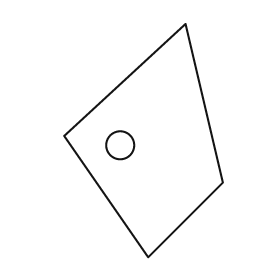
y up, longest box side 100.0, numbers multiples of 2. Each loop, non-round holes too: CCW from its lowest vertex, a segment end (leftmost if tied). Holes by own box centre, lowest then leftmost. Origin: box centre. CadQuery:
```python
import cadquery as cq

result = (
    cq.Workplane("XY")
    .moveTo(2.0, -50.0)
    .lineTo(34.0, -18.0)
    .lineTo(18.0, 50.0)
    .lineTo(-34.0, 2.0)
    .close()
    .moveTo(-10.0, -2.0)
    .circle(6.0)
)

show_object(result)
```